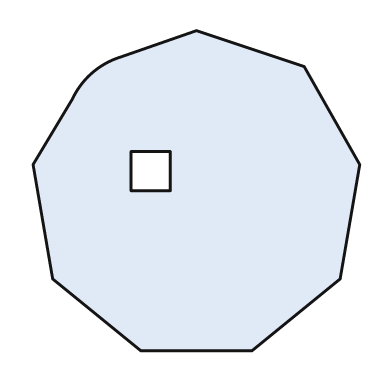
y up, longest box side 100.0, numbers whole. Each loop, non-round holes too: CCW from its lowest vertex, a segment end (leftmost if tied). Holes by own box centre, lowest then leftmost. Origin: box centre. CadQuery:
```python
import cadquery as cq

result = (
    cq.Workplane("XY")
    .moveTo(-17.0, -49.0)
    .lineTo(17.0, -49.0)
    .lineTo(44.0, -27.0)
    .lineTo(50.0, 8.0)
    .lineTo(33.0, 38.0)
    .lineTo(0.0, 49.0)
    .lineTo(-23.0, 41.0)
    .threePointArc((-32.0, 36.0), (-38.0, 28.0))
    .lineTo(-50.0, 8.0)
    .lineTo(-44.0, -27.0)
    .close()
    .moveTo(-20.0, 0.0)
    .lineTo(-8.0, 0.0)
    .lineTo(-8.0, 12.0)
    .lineTo(-20.0, 12.0)
    .close()
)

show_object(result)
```